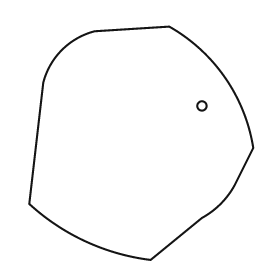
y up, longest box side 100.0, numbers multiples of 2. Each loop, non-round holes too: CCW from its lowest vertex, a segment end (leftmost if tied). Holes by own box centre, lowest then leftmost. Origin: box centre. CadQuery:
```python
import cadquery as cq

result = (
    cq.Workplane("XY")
    .moveTo(4.0, -50.0)
    .lineTo(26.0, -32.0)
    .threePointArc((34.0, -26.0), (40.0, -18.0))
    .lineTo(48.0, -2.0)
    .threePointArc((36.0, 28.0), (12.0, 50.0))
    .lineTo(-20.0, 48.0)
    .threePointArc((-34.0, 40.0), (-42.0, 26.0))
    .lineTo(-48.0, -26.0)
    .threePointArc((-24.0, -42.0), (4.0, -50.0))
    .close()
    .moveTo(26.0, 16.0)
    .circle(2.0)
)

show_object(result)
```